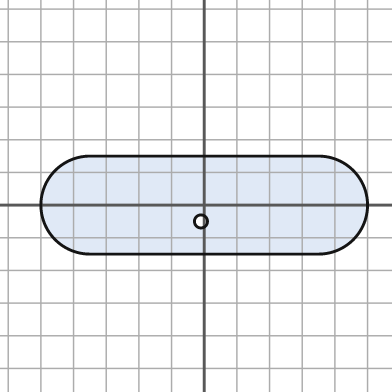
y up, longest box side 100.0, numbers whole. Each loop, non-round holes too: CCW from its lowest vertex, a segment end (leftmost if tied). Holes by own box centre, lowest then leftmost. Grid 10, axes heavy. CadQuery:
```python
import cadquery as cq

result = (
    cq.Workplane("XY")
    .moveTo(-35.0, -15.0)
    .lineTo(35.0, -15.0)
    .threePointArc((50.0, 0.0), (35.0, 15.0))
    .lineTo(-35.0, 15.0)
    .threePointArc((-50.0, 0.0), (-35.0, -15.0))
    .close()
    .moveTo(-1.0, -5.0)
    .circle(2.0)
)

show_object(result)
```